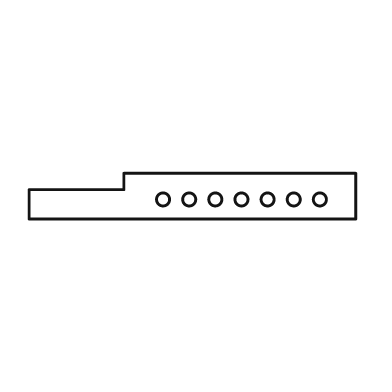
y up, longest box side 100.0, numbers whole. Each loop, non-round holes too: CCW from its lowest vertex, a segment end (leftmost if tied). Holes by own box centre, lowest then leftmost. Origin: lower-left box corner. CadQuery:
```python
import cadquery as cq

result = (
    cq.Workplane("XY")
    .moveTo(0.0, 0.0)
    .lineTo(100.0, 0.0)
    .lineTo(100.0, 14.0)
    .lineTo(29.0, 14.0)
    .lineTo(29.0, 9.0)
    .lineTo(0.0, 9.0)
    .close()
    .moveTo(41.0, 6.0)
    .circle(2.0)
    .moveTo(49.0, 6.0)
    .circle(2.0)
    .moveTo(57.0, 6.0)
    .circle(2.0)
    .moveTo(65.0, 6.0)
    .circle(2.0)
    .moveTo(73.0, 6.0)
    .circle(2.0)
    .moveTo(81.0, 6.0)
    .circle(2.0)
    .moveTo(89.0, 6.0)
    .circle(2.0)
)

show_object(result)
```